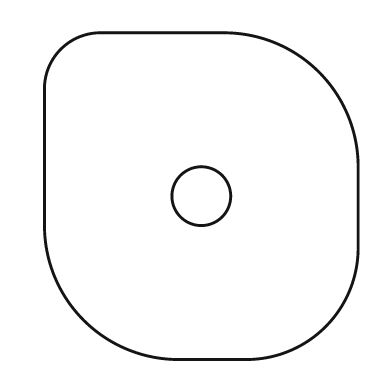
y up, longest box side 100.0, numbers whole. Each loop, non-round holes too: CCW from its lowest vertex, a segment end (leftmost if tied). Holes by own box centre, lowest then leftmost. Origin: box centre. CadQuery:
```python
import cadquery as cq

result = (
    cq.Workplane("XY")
    .moveTo(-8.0, -50.0)
    .lineTo(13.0, -50.0)
    .threePointArc((38.0, -40.0), (48.0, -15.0))
    .lineTo(48.0, 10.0)
    .threePointArc((36.0, 38.0), (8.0, 50.0))
    .lineTo(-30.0, 50.0)
    .threePointArc((-43.0, 45.0), (-48.0, 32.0))
    .lineTo(-48.0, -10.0)
    .threePointArc((-36.0, -38.0), (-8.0, -50.0))
    .close()
    .moveTo(0.0, 0.0)
    .circle(9.0)
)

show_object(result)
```